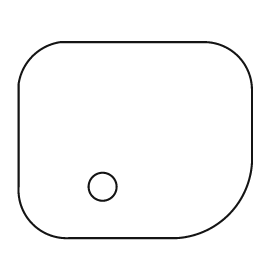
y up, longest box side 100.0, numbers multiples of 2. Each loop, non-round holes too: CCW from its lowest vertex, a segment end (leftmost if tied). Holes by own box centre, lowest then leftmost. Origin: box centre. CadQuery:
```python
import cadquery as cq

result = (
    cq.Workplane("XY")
    .moveTo(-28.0, -42.0)
    .lineTo(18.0, -42.0)
    .threePointArc((40.0, -32.0), (50.0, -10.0))
    .lineTo(50.0, 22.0)
    .threePointArc((44.0, 36.0), (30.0, 42.0))
    .lineTo(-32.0, 42.0)
    .threePointArc((-44.0, 36.0), (-50.0, 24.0))
    .lineTo(-50.0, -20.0)
    .threePointArc((-44.0, -36.0), (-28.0, -42.0))
    .close()
    .moveTo(-14.0, -20.0)
    .circle(6.0)
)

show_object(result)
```